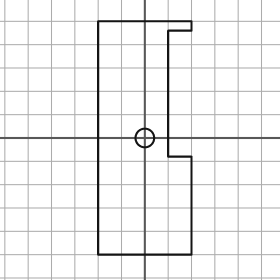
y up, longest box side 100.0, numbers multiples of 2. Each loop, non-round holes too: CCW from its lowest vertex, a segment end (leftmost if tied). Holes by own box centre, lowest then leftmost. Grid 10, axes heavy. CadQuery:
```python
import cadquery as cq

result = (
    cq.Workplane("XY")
    .moveTo(-20.0, -50.0)
    .lineTo(20.0, -50.0)
    .lineTo(20.0, -8.0)
    .lineTo(10.0, -8.0)
    .lineTo(10.0, 46.0)
    .lineTo(20.0, 46.0)
    .lineTo(20.0, 50.0)
    .lineTo(-20.0, 50.0)
    .close()
    .moveTo(0.0, 0.0)
    .circle(4.0)
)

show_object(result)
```